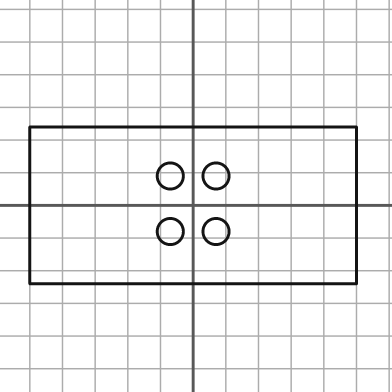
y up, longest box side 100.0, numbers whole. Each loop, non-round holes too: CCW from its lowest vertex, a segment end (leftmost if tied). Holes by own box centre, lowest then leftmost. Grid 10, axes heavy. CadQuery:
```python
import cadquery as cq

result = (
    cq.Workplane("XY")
    .moveTo(-50.0, -24.0)
    .lineTo(50.0, -24.0)
    .lineTo(50.0, 24.0)
    .lineTo(-50.0, 24.0)
    .close()
    .moveTo(-7.0, -8.0)
    .circle(4.0)
    .moveTo(7.0, -8.0)
    .circle(4.0)
    .moveTo(-7.0, 9.0)
    .circle(4.0)
    .moveTo(7.0, 9.0)
    .circle(4.0)
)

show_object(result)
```